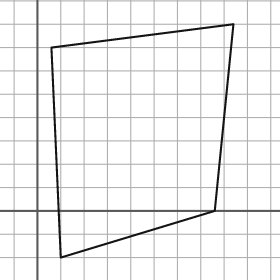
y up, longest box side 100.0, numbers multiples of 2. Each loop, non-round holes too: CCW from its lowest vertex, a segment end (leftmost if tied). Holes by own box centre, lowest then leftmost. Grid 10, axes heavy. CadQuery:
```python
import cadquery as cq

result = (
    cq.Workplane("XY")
    .moveTo(10.0, -20.0)
    .lineTo(76.0, 0.0)
    .lineTo(84.0, 80.0)
    .lineTo(6.0, 70.0)
    .close()
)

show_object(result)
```